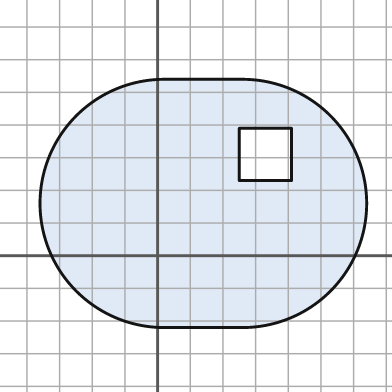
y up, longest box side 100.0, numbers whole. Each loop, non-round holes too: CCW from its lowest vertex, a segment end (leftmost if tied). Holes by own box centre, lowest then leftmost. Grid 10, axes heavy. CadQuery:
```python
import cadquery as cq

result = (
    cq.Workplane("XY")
    .moveTo(2.0, -22.0)
    .lineTo(26.0, -22.0)
    .threePointArc((64.0, 16.0), (26.0, 54.0))
    .lineTo(2.0, 54.0)
    .threePointArc((-36.0, 16.0), (2.0, -22.0))
    .close()
    .moveTo(25.0, 23.0)
    .lineTo(41.0, 23.0)
    .lineTo(41.0, 39.0)
    .lineTo(25.0, 39.0)
    .close()
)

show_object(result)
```